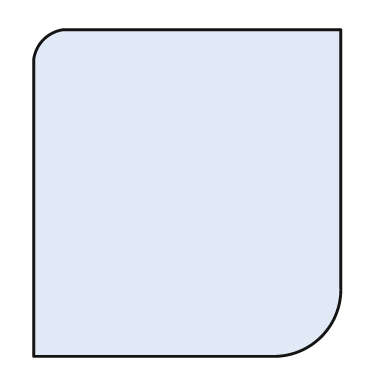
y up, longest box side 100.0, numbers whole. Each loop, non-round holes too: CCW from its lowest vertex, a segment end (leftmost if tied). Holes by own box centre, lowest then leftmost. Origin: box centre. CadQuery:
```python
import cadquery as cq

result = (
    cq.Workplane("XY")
    .moveTo(-47.0, -50.0)
    .lineTo(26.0, -50.0)
    .threePointArc((41.0, -44.0), (47.0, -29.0))
    .lineTo(47.0, 50.0)
    .lineTo(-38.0, 50.0)
    .threePointArc((-44.0, 47.0), (-47.0, 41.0))
    .close()
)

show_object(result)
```